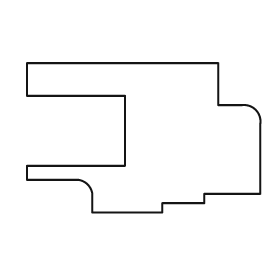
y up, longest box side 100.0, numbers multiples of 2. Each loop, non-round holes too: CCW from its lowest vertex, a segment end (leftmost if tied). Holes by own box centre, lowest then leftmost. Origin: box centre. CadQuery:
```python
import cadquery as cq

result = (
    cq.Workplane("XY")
    .moveTo(-22.0, -32.0)
    .lineTo(8.0, -32.0)
    .lineTo(8.0, -28.0)
    .lineTo(26.0, -28.0)
    .lineTo(26.0, -24.0)
    .lineTo(50.0, -24.0)
    .lineTo(50.0, 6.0)
    .threePointArc((48.0, 12.0), (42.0, 14.0))
    .lineTo(32.0, 14.0)
    .lineTo(32.0, 32.0)
    .lineTo(-50.0, 32.0)
    .lineTo(-50.0, 18.0)
    .lineTo(-8.0, 18.0)
    .lineTo(-8.0, -12.0)
    .lineTo(-50.0, -12.0)
    .lineTo(-50.0, -18.0)
    .lineTo(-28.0, -18.0)
    .threePointArc((-24.0, -20.0), (-22.0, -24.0))
    .close()
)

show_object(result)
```